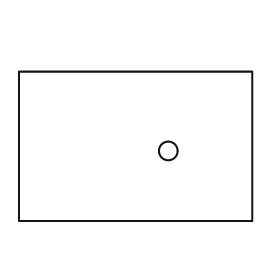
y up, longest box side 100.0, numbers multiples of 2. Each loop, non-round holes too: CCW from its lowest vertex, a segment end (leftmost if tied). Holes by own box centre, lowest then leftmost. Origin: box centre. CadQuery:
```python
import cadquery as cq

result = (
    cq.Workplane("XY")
    .moveTo(-50.0, -32.0)
    .lineTo(50.0, -32.0)
    .lineTo(50.0, 32.0)
    .lineTo(-50.0, 32.0)
    .close()
    .moveTo(14.0, -2.0)
    .circle(4.0)
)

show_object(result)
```